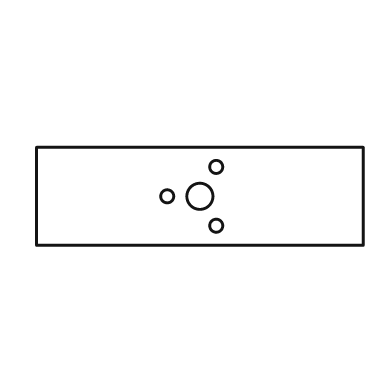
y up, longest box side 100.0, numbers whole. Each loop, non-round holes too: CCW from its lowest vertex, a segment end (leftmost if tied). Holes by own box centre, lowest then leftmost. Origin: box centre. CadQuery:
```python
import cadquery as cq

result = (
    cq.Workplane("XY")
    .moveTo(-50.0, -15.0)
    .lineTo(50.0, -15.0)
    .lineTo(50.0, 15.0)
    .lineTo(-50.0, 15.0)
    .close()
    .moveTo(5.0, -9.0)
    .circle(2.0)
    .moveTo(-10.0, 0.0)
    .circle(2.0)
    .moveTo(0.0, 0.0)
    .circle(4.0)
    .moveTo(5.0, 9.0)
    .circle(2.0)
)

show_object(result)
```